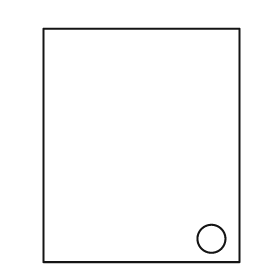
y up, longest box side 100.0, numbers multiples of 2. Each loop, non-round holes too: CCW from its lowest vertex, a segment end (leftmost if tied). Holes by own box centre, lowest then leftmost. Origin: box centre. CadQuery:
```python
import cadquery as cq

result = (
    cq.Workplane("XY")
    .moveTo(-42.0, -50.0)
    .lineTo(42.0, -50.0)
    .lineTo(42.0, 50.0)
    .lineTo(-42.0, 50.0)
    .close()
    .moveTo(30.0, -40.0)
    .circle(6.0)
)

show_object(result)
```